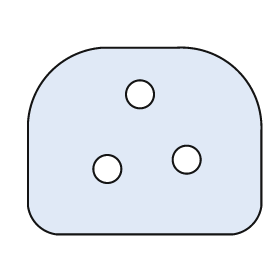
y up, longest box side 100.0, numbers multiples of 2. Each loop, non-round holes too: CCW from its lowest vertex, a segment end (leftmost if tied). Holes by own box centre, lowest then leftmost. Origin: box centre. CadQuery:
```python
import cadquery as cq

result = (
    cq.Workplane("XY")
    .moveTo(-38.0, -40.0)
    .lineTo(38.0, -40.0)
    .threePointArc((46.0, -36.0), (50.0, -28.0))
    .lineTo(50.0, 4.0)
    .threePointArc((40.0, 30.0), (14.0, 40.0))
    .lineTo(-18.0, 40.0)
    .threePointArc((-40.0, 30.0), (-50.0, 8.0))
    .lineTo(-50.0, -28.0)
    .threePointArc((-46.0, -36.0), (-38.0, -40.0))
    .close()
    .moveTo(-16.0, -12.0)
    .circle(6.0)
    .moveTo(18.0, -8.0)
    .circle(6.0)
    .moveTo(-2.0, 20.0)
    .circle(6.0)
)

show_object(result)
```